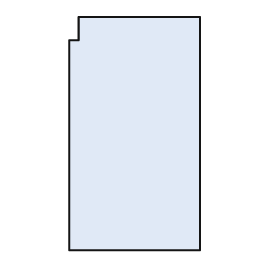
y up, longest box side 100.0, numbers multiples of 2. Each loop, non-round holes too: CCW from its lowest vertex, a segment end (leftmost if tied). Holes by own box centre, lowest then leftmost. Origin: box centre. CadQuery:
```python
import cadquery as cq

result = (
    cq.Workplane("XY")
    .moveTo(-28.0, -50.0)
    .lineTo(28.0, -50.0)
    .lineTo(28.0, 50.0)
    .lineTo(-24.0, 50.0)
    .lineTo(-24.0, 40.0)
    .lineTo(-28.0, 40.0)
    .close()
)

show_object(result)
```